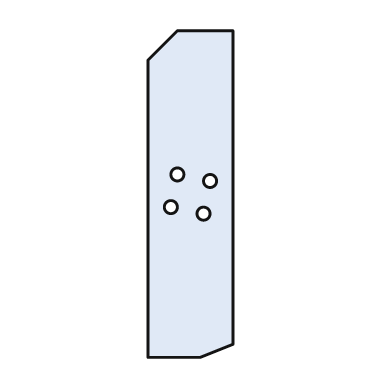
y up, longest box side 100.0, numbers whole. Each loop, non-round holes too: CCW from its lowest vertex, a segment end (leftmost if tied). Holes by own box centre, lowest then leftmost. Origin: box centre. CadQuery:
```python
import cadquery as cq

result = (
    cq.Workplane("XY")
    .moveTo(-13.0, -50.0)
    .lineTo(3.0, -50.0)
    .lineTo(13.0, -46.0)
    .lineTo(13.0, 50.0)
    .lineTo(-4.0, 50.0)
    .lineTo(-13.0, 41.0)
    .close()
    .moveTo(4.0, -6.0)
    .circle(2.0)
    .moveTo(-6.0, -4.0)
    .circle(2.0)
    .moveTo(6.0, 4.0)
    .circle(2.0)
    .moveTo(-4.0, 6.0)
    .circle(2.0)
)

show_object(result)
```